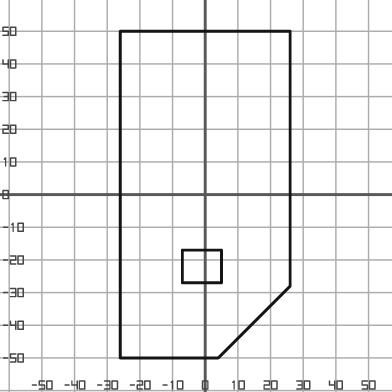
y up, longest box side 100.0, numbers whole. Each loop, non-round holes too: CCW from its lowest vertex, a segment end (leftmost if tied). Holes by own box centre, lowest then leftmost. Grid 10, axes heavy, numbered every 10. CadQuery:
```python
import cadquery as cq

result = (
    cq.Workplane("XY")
    .moveTo(-26.0, -50.0)
    .lineTo(4.0, -50.0)
    .lineTo(26.0, -28.0)
    .lineTo(26.0, 50.0)
    .lineTo(-26.0, 50.0)
    .close()
    .moveTo(-7.0, -27.0)
    .lineTo(5.0, -27.0)
    .lineTo(5.0, -17.0)
    .lineTo(-7.0, -17.0)
    .close()
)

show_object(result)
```